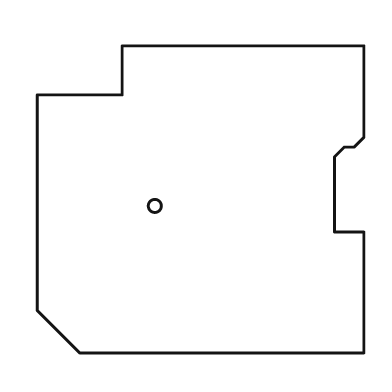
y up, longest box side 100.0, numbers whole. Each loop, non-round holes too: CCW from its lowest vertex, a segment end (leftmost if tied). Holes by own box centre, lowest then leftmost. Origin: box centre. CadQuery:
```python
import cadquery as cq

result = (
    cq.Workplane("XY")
    .moveTo(-37.0, -47.0)
    .lineTo(50.0, -47.0)
    .lineTo(50.0, -10.0)
    .lineTo(41.0, -10.0)
    .lineTo(41.0, 13.0)
    .lineTo(44.0, 16.0)
    .lineTo(47.0, 16.0)
    .lineTo(50.0, 19.0)
    .lineTo(50.0, 47.0)
    .lineTo(-24.0, 47.0)
    .lineTo(-24.0, 32.0)
    .lineTo(-50.0, 32.0)
    .lineTo(-50.0, -34.0)
    .close()
    .moveTo(-14.0, -2.0)
    .circle(2.0)
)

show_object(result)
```